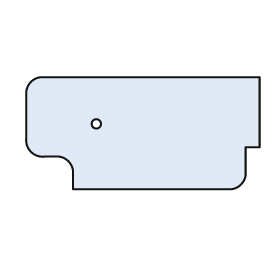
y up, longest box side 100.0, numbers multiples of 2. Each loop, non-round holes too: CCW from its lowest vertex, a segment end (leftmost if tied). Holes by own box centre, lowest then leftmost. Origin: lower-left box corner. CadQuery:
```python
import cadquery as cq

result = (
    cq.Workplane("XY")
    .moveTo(20.0, 0.0)
    .lineTo(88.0, 0.0)
    .threePointArc((92.0, 2.0), (94.0, 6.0))
    .lineTo(94.0, 18.0)
    .lineTo(100.0, 18.0)
    .lineTo(100.0, 48.0)
    .lineTo(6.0, 48.0)
    .threePointArc((2.0, 46.0), (0.0, 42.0))
    .lineTo(0.0, 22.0)
    .threePointArc((2.0, 16.0), (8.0, 14.0))
    .lineTo(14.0, 14.0)
    .threePointArc((18.0, 12.0), (20.0, 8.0))
    .close()
    .moveTo(30.0, 28.0)
    .circle(2.0)
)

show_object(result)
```